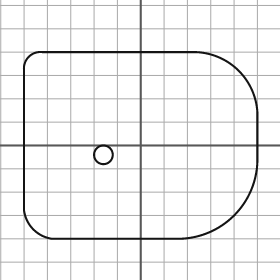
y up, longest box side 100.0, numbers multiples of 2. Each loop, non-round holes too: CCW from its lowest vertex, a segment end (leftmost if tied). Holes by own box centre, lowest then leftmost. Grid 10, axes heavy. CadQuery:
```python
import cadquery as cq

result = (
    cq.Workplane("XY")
    .moveTo(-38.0, -40.0)
    .lineTo(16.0, -40.0)
    .threePointArc((40.0, -30.0), (50.0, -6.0))
    .lineTo(50.0, 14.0)
    .threePointArc((42.0, 32.0), (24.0, 40.0))
    .lineTo(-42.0, 40.0)
    .threePointArc((-48.0, 38.0), (-50.0, 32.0))
    .lineTo(-50.0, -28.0)
    .threePointArc((-46.0, -36.0), (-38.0, -40.0))
    .close()
    .moveTo(-16.0, -4.0)
    .circle(4.0)
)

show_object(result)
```